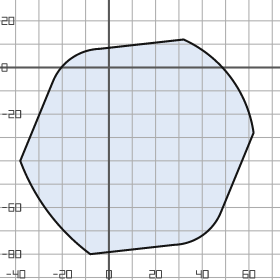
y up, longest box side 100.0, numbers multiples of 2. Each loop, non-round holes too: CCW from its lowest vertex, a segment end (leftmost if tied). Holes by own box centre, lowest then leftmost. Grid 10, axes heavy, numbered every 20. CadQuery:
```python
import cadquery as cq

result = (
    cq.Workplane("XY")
    .moveTo(-8.0, -80.0)
    .lineTo(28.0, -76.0)
    .threePointArc((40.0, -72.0), (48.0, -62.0))
    .lineTo(62.0, -28.0)
    .threePointArc((52.0, -4.0), (32.0, 12.0))
    .lineTo(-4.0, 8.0)
    .threePointArc((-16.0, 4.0), (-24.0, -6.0))
    .lineTo(-38.0, -40.0)
    .threePointArc((-26.0, -62.0), (-8.0, -80.0))
    .close()
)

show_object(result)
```